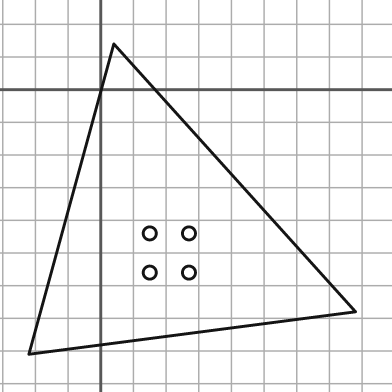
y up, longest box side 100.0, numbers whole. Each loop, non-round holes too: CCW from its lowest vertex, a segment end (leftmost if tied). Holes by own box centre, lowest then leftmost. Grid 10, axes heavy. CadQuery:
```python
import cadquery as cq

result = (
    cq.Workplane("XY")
    .moveTo(-22.0, -81.0)
    .lineTo(78.0, -68.0)
    .lineTo(4.0, 14.0)
    .close()
    .moveTo(15.0, -56.0)
    .circle(2.0)
    .moveTo(27.0, -56.0)
    .circle(2.0)
    .moveTo(15.0, -44.0)
    .circle(2.0)
    .moveTo(27.0, -44.0)
    .circle(2.0)
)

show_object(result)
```